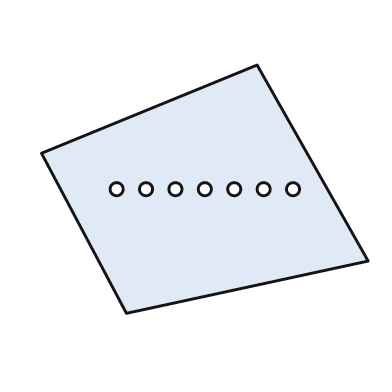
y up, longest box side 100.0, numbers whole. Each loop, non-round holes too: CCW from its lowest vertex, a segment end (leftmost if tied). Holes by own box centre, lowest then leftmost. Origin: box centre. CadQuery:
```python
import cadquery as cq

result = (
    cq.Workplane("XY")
    .moveTo(-24.0, -38.0)
    .lineTo(50.0, -22.0)
    .lineTo(16.0, 38.0)
    .lineTo(-50.0, 11.0)
    .close()
    .moveTo(-27.0, 0.0)
    .circle(2.0)
    .moveTo(-18.0, 0.0)
    .circle(2.0)
    .moveTo(-9.0, 0.0)
    .circle(2.0)
    .moveTo(0.0, 0.0)
    .circle(2.0)
    .moveTo(9.0, 0.0)
    .circle(2.0)
    .moveTo(18.0, 0.0)
    .circle(2.0)
    .moveTo(27.0, 0.0)
    .circle(2.0)
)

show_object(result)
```